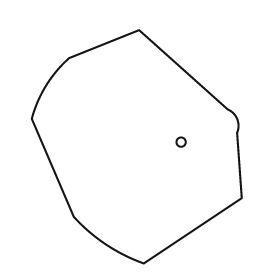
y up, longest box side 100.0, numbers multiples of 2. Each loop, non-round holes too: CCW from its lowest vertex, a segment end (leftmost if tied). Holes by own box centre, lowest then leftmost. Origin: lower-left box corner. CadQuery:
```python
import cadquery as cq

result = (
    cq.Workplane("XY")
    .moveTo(48.0, 0.0)
    .lineTo(90.0, 28.0)
    .lineTo(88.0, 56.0)
    .threePointArc((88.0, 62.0), (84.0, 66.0))
    .lineTo(46.0, 100.0)
    .lineTo(16.0, 88.0)
    .threePointArc((6.0, 76.0), (0.0, 62.0))
    .lineTo(18.0, 20.0)
    .threePointArc((32.0, 8.0), (48.0, 0.0))
    .close()
    .moveTo(64.0, 52.0)
    .circle(2.0)
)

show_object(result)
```